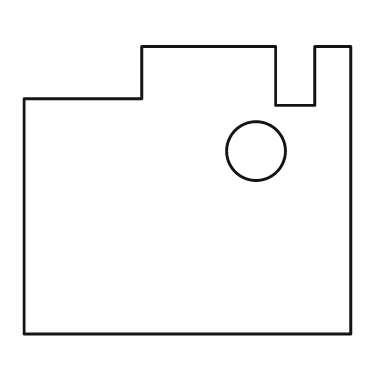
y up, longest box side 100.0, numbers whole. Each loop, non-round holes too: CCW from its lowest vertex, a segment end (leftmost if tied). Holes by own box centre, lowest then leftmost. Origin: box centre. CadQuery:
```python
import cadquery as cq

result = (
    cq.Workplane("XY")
    .moveTo(-50.0, -44.0)
    .lineTo(50.0, -44.0)
    .lineTo(50.0, 44.0)
    .lineTo(39.0, 44.0)
    .lineTo(39.0, 26.0)
    .lineTo(27.0, 26.0)
    .lineTo(27.0, 44.0)
    .lineTo(-14.0, 44.0)
    .lineTo(-14.0, 28.0)
    .lineTo(-50.0, 28.0)
    .close()
    .moveTo(21.0, 12.0)
    .circle(9.0)
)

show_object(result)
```